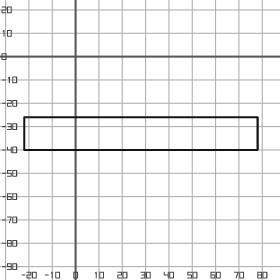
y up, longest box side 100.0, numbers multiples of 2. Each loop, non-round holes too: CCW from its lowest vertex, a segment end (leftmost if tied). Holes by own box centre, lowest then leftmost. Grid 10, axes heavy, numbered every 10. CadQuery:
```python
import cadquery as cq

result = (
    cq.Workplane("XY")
    .moveTo(-22.0, -40.0)
    .lineTo(78.0, -40.0)
    .lineTo(78.0, -26.0)
    .lineTo(-22.0, -26.0)
    .close()
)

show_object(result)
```